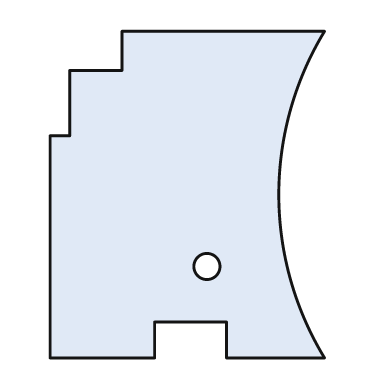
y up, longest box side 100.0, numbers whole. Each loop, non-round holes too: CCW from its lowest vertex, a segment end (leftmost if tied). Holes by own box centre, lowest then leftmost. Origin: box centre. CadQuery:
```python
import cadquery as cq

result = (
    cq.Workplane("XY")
    .moveTo(-42.0, -50.0)
    .lineTo(-10.0, -50.0)
    .lineTo(-10.0, -39.0)
    .lineTo(12.0, -39.0)
    .lineTo(12.0, -50.0)
    .lineTo(42.0, -50.0)
    .threePointArc((28.0, 0.0), (42.0, 50.0))
    .lineTo(-20.0, 50.0)
    .lineTo(-20.0, 38.0)
    .lineTo(-36.0, 38.0)
    .lineTo(-36.0, 18.0)
    .lineTo(-42.0, 18.0)
    .close()
    .moveTo(6.0, -22.0)
    .circle(4.0)
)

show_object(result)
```